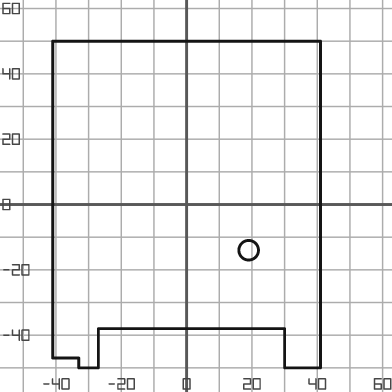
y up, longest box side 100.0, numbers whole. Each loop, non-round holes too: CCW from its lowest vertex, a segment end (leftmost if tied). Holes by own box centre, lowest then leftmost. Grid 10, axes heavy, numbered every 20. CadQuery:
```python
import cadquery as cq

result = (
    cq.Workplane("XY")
    .moveTo(-33.0, -50.0)
    .lineTo(-27.0, -50.0)
    .lineTo(-27.0, -38.0)
    .lineTo(30.0, -38.0)
    .lineTo(30.0, -50.0)
    .lineTo(41.0, -50.0)
    .lineTo(41.0, 50.0)
    .lineTo(-41.0, 50.0)
    .lineTo(-41.0, -47.0)
    .lineTo(-33.0, -47.0)
    .close()
    .moveTo(19.0, -14.0)
    .circle(3.0)
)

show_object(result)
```